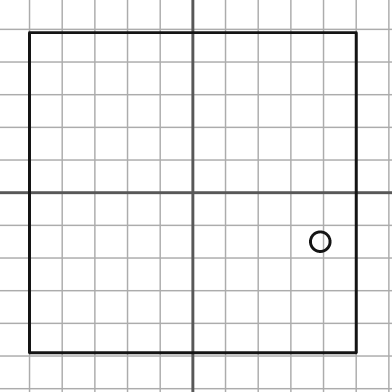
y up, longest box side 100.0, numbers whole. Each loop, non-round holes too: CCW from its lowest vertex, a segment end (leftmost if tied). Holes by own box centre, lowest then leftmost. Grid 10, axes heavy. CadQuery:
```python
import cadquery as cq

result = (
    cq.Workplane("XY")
    .moveTo(-50.0, -49.0)
    .lineTo(50.0, -49.0)
    .lineTo(50.0, 49.0)
    .lineTo(-50.0, 49.0)
    .close()
    .moveTo(39.0, -15.0)
    .circle(3.0)
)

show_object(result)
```